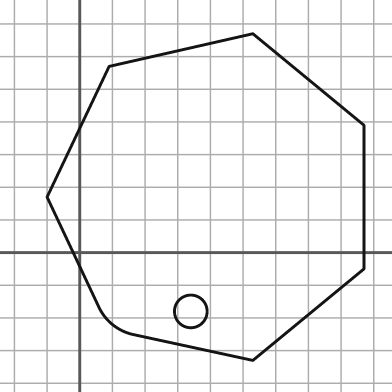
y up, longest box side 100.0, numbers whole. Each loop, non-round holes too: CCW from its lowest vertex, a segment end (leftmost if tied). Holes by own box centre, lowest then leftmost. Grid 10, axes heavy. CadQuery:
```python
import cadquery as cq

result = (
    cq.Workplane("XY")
    .moveTo(53.0, -33.0)
    .lineTo(87.0, -5.0)
    .lineTo(87.0, 39.0)
    .lineTo(53.0, 67.0)
    .lineTo(9.0, 57.0)
    .lineTo(-10.0, 17.0)
    .lineTo(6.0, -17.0)
    .threePointArc((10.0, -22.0), (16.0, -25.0))
    .close()
    .moveTo(34.0, -18.0)
    .circle(5.0)
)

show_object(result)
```